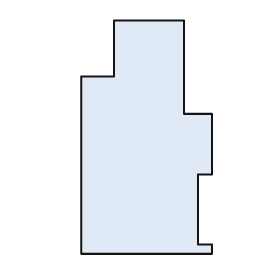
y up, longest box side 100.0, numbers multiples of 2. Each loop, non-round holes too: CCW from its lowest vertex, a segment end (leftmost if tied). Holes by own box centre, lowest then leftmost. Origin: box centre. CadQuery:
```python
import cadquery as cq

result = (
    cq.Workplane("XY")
    .moveTo(-28.0, -50.0)
    .lineTo(28.0, -50.0)
    .lineTo(28.0, -46.0)
    .lineTo(22.0, -46.0)
    .lineTo(22.0, -16.0)
    .lineTo(28.0, -16.0)
    .lineTo(28.0, 10.0)
    .lineTo(16.0, 10.0)
    .lineTo(16.0, 50.0)
    .lineTo(-14.0, 50.0)
    .lineTo(-14.0, 26.0)
    .lineTo(-28.0, 26.0)
    .close()
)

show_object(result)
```